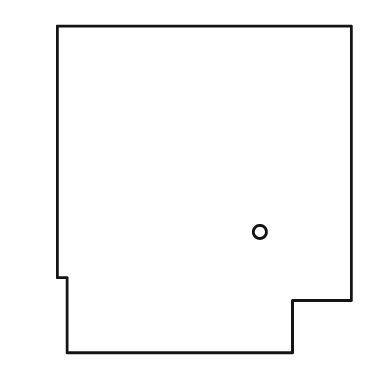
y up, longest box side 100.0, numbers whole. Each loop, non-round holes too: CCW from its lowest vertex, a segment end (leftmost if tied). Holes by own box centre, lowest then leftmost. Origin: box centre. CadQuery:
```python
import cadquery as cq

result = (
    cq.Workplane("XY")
    .moveTo(-42.0, -50.0)
    .lineTo(27.0, -50.0)
    .lineTo(27.0, -34.0)
    .lineTo(45.0, -34.0)
    .lineTo(45.0, 50.0)
    .lineTo(-45.0, 50.0)
    .lineTo(-45.0, -27.0)
    .lineTo(-42.0, -27.0)
    .close()
    .moveTo(17.0, -13.0)
    .circle(2.0)
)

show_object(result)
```